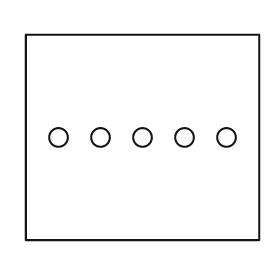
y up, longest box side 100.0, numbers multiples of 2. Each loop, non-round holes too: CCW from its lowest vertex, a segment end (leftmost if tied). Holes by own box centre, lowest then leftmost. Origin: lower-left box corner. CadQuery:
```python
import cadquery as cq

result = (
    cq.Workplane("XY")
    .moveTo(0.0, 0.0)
    .lineTo(100.0, 0.0)
    .lineTo(100.0, 88.0)
    .lineTo(0.0, 88.0)
    .close()
    .moveTo(14.0, 44.0)
    .circle(4.0)
    .moveTo(32.0, 44.0)
    .circle(4.0)
    .moveTo(50.0, 44.0)
    .circle(4.0)
    .moveTo(68.0, 44.0)
    .circle(4.0)
    .moveTo(86.0, 44.0)
    .circle(4.0)
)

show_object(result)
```